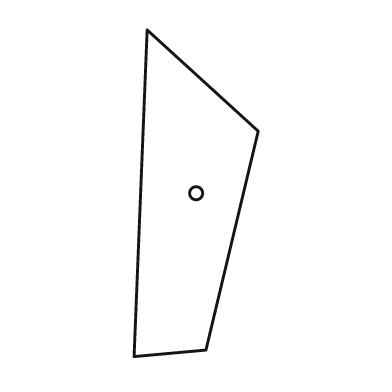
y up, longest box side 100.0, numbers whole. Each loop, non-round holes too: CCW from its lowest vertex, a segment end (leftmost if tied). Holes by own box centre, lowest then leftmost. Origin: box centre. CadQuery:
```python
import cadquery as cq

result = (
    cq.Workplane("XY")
    .moveTo(-19.0, -50.0)
    .lineTo(3.0, -48.0)
    .lineTo(19.0, 19.0)
    .lineTo(-15.0, 50.0)
    .close()
    .moveTo(0.0, 0.0)
    .circle(2.0)
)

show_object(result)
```